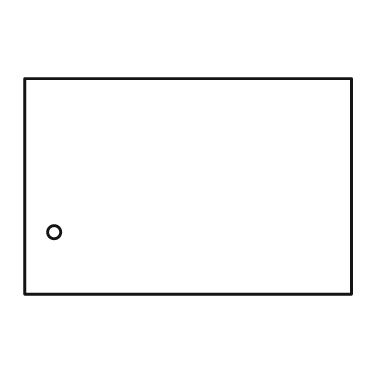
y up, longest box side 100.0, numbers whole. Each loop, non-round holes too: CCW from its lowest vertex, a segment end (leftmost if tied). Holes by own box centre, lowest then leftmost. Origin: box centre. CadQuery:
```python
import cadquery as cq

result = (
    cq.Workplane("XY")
    .moveTo(-50.0, -33.0)
    .lineTo(50.0, -33.0)
    .lineTo(50.0, 33.0)
    .lineTo(-50.0, 33.0)
    .close()
    .moveTo(-41.0, -14.0)
    .circle(2.0)
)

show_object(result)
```